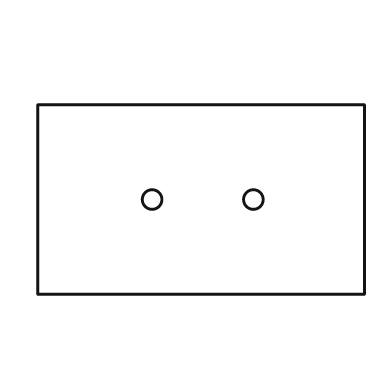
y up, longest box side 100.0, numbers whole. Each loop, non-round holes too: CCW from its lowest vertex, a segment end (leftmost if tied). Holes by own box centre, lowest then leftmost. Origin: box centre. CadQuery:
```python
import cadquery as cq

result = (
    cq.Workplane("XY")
    .moveTo(-50.0, -29.0)
    .lineTo(50.0, -29.0)
    .lineTo(50.0, 29.0)
    .lineTo(-50.0, 29.0)
    .close()
    .moveTo(-15.0, 0.0)
    .circle(3.0)
    .moveTo(16.0, 0.0)
    .circle(3.0)
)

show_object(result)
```